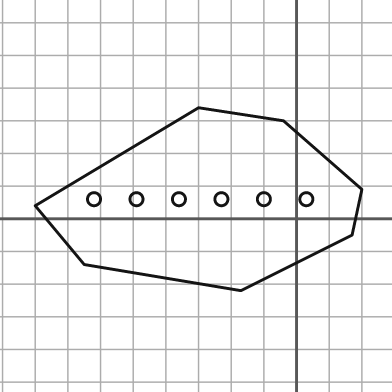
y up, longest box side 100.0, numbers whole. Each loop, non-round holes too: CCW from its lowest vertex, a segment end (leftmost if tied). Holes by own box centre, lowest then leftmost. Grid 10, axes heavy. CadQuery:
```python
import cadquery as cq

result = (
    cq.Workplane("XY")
    .moveTo(-17.0, -22.0)
    .lineTo(17.0, -5.0)
    .lineTo(20.0, 9.0)
    .lineTo(-4.0, 30.0)
    .lineTo(-30.0, 34.0)
    .lineTo(-80.0, 4.0)
    .lineTo(-65.0, -14.0)
    .close()
    .moveTo(-62.0, 6.0)
    .circle(2.0)
    .moveTo(-49.0, 6.0)
    .circle(2.0)
    .moveTo(-36.0, 6.0)
    .circle(2.0)
    .moveTo(-23.0, 6.0)
    .circle(2.0)
    .moveTo(-10.0, 6.0)
    .circle(2.0)
    .moveTo(3.0, 6.0)
    .circle(2.0)
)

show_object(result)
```